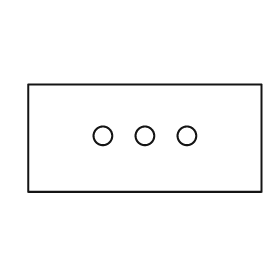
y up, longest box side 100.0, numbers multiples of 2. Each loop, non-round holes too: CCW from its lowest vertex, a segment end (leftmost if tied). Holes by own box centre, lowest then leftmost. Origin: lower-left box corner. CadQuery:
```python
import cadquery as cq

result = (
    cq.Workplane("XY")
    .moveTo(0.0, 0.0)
    .lineTo(100.0, 0.0)
    .lineTo(100.0, 46.0)
    .lineTo(0.0, 46.0)
    .close()
    .moveTo(32.0, 24.0)
    .circle(4.0)
    .moveTo(50.0, 24.0)
    .circle(4.0)
    .moveTo(68.0, 24.0)
    .circle(4.0)
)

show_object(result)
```